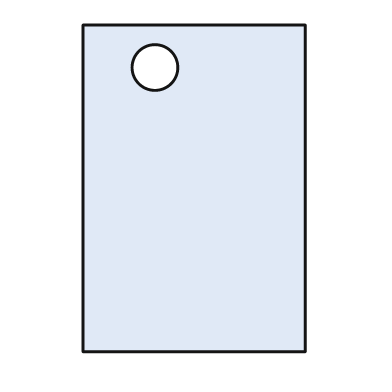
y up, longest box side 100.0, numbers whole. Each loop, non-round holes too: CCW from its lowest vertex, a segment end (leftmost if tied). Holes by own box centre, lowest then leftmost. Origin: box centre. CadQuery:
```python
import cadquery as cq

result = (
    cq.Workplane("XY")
    .moveTo(-34.0, -50.0)
    .lineTo(34.0, -50.0)
    .lineTo(34.0, 50.0)
    .lineTo(-34.0, 50.0)
    .close()
    .moveTo(-12.0, 37.0)
    .circle(7.0)
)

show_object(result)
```